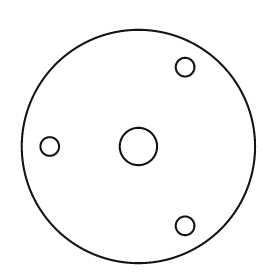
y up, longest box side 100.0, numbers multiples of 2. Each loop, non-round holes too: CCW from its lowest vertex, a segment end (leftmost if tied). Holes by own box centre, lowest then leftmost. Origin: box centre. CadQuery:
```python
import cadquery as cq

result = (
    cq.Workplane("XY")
    .moveTo(0.0, 0.0)
    .circle(50.0)
    .moveTo(20.0, -34.0)
    .circle(4.0)
    .moveTo(-38.0, 0.0)
    .circle(4.0)
    .moveTo(0.0, 0.0)
    .circle(8.0)
    .moveTo(20.0, 34.0)
    .circle(4.0)
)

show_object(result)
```